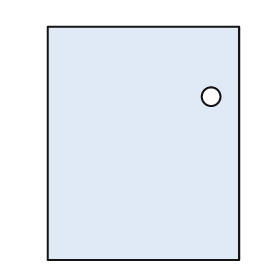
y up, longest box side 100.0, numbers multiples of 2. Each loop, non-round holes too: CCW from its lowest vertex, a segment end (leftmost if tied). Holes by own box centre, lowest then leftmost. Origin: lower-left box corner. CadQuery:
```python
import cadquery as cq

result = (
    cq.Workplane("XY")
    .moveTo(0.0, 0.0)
    .lineTo(82.0, 0.0)
    .lineTo(82.0, 100.0)
    .lineTo(0.0, 100.0)
    .close()
    .moveTo(70.0, 70.0)
    .circle(4.0)
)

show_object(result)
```